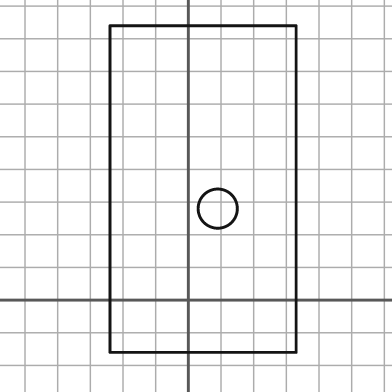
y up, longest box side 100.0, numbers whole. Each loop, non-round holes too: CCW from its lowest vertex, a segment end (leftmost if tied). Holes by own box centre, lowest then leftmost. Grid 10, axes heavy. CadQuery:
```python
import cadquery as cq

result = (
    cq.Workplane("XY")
    .moveTo(-24.0, -16.0)
    .lineTo(33.0, -16.0)
    .lineTo(33.0, 84.0)
    .lineTo(-24.0, 84.0)
    .close()
    .moveTo(9.0, 28.0)
    .circle(6.0)
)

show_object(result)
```